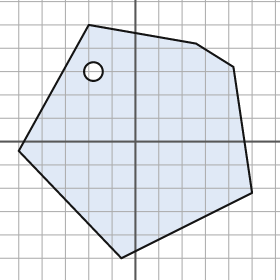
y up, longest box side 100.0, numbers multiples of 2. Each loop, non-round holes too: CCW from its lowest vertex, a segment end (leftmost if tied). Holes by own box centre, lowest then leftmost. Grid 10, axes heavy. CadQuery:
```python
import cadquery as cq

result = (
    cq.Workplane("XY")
    .moveTo(-6.0, -50.0)
    .lineTo(50.0, -22.0)
    .lineTo(42.0, 32.0)
    .lineTo(26.0, 42.0)
    .lineTo(-20.0, 50.0)
    .lineTo(-50.0, -4.0)
    .close()
    .moveTo(-18.0, 30.0)
    .circle(4.0)
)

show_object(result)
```